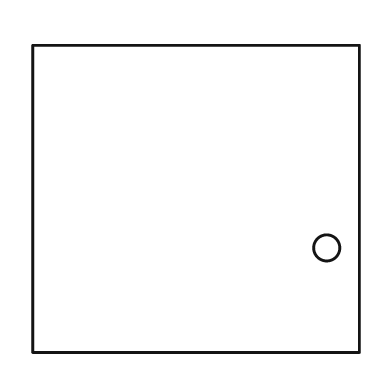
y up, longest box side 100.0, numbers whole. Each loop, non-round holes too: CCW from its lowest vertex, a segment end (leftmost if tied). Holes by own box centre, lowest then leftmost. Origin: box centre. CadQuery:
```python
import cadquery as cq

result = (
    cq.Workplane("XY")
    .moveTo(-50.0, -47.0)
    .lineTo(50.0, -47.0)
    .lineTo(50.0, 47.0)
    .lineTo(-50.0, 47.0)
    .close()
    .moveTo(40.0, -15.0)
    .circle(4.0)
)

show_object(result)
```